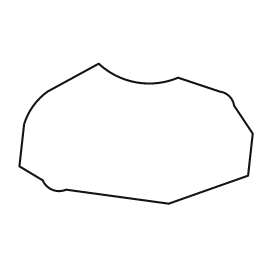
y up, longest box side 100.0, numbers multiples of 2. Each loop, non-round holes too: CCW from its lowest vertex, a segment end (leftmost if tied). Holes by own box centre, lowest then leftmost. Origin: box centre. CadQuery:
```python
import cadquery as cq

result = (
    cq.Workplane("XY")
    .moveTo(14.0, -30.0)
    .lineTo(48.0, -18.0)
    .lineTo(50.0, 0.0)
    .lineTo(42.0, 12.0)
    .threePointArc((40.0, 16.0), (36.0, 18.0))
    .lineTo(18.0, 24.0)
    .threePointArc((0.0, 22.0), (-16.0, 30.0))
    .lineTo(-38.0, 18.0)
    .threePointArc((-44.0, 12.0), (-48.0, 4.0))
    .lineTo(-50.0, -14.0)
    .lineTo(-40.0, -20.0)
    .threePointArc((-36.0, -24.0), (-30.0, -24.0))
    .close()
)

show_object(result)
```